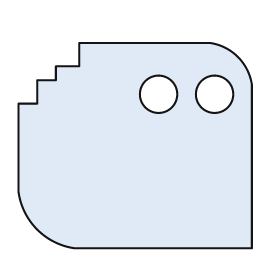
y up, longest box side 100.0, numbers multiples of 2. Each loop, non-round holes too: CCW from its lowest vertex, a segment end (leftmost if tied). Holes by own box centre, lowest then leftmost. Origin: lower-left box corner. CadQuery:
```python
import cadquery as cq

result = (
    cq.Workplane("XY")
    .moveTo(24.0, 0.0)
    .lineTo(100.0, 0.0)
    .lineTo(100.0, 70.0)
    .threePointArc((94.0, 82.0), (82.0, 88.0))
    .lineTo(26.0, 88.0)
    .lineTo(26.0, 78.0)
    .lineTo(16.0, 78.0)
    .lineTo(16.0, 72.0)
    .lineTo(8.0, 72.0)
    .lineTo(8.0, 62.0)
    .lineTo(0.0, 62.0)
    .lineTo(0.0, 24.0)
    .threePointArc((8.0, 8.0), (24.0, 0.0))
    .close()
    .moveTo(60.0, 66.0)
    .circle(8.0)
    .moveTo(84.0, 66.0)
    .circle(8.0)
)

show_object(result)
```